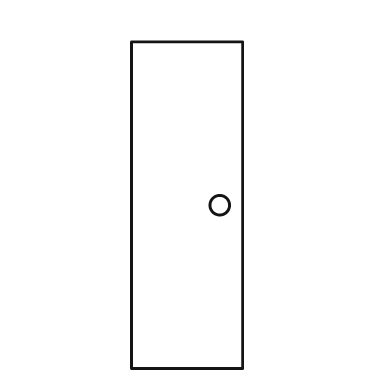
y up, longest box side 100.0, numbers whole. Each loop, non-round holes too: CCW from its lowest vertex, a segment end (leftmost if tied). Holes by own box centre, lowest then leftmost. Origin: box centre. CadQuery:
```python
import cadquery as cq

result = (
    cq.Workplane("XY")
    .moveTo(-17.0, -50.0)
    .lineTo(17.0, -50.0)
    .lineTo(17.0, 50.0)
    .lineTo(-17.0, 50.0)
    .close()
    .moveTo(10.0, 0.0)
    .circle(3.0)
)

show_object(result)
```